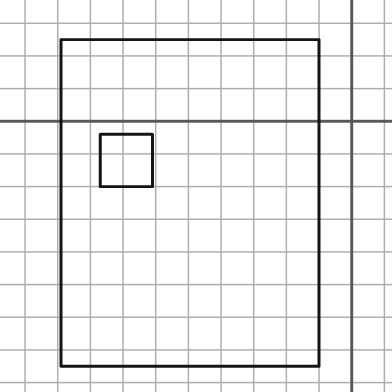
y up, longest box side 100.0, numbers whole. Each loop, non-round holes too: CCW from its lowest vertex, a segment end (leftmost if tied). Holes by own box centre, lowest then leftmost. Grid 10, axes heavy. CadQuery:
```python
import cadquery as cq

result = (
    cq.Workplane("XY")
    .moveTo(-89.0, -75.0)
    .lineTo(-10.0, -75.0)
    .lineTo(-10.0, 25.0)
    .lineTo(-89.0, 25.0)
    .close()
    .moveTo(-77.0, -20.0)
    .lineTo(-61.0, -20.0)
    .lineTo(-61.0, -4.0)
    .lineTo(-77.0, -4.0)
    .close()
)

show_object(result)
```